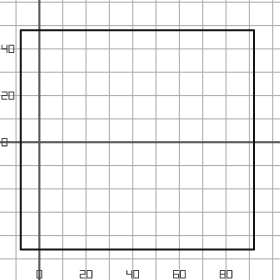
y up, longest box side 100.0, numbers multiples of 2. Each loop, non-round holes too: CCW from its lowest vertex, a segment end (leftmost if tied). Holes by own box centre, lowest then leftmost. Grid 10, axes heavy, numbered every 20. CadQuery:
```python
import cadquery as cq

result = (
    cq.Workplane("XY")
    .moveTo(-8.0, -46.0)
    .lineTo(92.0, -46.0)
    .lineTo(92.0, 48.0)
    .lineTo(-8.0, 48.0)
    .close()
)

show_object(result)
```